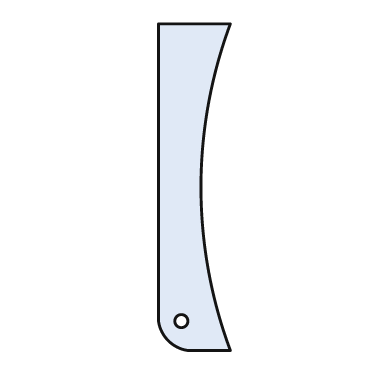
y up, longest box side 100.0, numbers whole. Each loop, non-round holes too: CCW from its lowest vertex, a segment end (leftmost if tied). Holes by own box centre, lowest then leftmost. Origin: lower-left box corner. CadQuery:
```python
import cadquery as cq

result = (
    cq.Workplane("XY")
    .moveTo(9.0, 0.0)
    .lineTo(22.0, 0.0)
    .threePointArc((13.0, 50.0), (22.0, 100.0))
    .lineTo(0.0, 100.0)
    .lineTo(0.0, 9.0)
    .threePointArc((3.0, 3.0), (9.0, 0.0))
    .close()
    .moveTo(7.0, 9.0)
    .circle(2.0)
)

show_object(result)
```